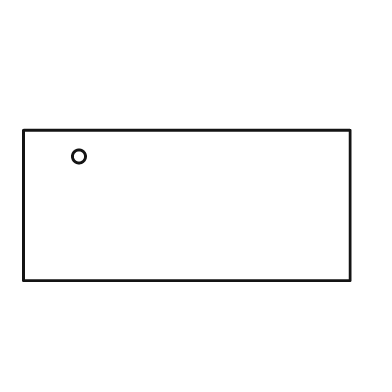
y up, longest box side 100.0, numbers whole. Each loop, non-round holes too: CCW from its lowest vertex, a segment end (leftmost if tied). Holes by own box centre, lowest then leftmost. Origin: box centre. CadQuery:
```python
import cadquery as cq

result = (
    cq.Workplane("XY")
    .moveTo(-50.0, -23.0)
    .lineTo(50.0, -23.0)
    .lineTo(50.0, 23.0)
    .lineTo(-50.0, 23.0)
    .close()
    .moveTo(-33.0, 15.0)
    .circle(2.0)
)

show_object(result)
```